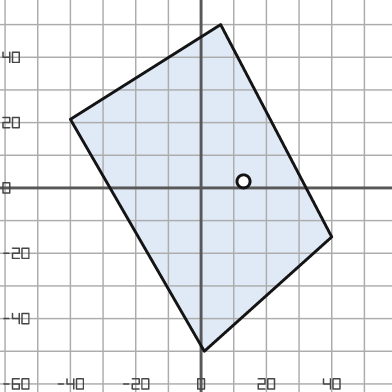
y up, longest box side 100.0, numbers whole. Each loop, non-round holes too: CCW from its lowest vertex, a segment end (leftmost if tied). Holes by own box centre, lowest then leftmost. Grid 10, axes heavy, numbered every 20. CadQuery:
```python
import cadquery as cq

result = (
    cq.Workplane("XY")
    .moveTo(1.0, -50.0)
    .lineTo(40.0, -15.0)
    .lineTo(6.0, 50.0)
    .lineTo(-40.0, 21.0)
    .close()
    .moveTo(13.0, 2.0)
    .circle(2.0)
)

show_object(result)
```